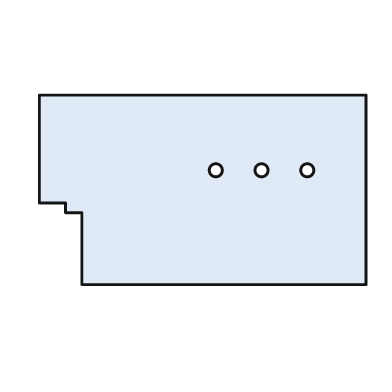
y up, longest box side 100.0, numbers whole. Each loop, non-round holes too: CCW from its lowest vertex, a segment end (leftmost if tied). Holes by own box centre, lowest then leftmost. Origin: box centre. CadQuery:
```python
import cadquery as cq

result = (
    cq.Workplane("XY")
    .moveTo(-37.0, -29.0)
    .lineTo(50.0, -29.0)
    .lineTo(50.0, 29.0)
    .lineTo(-50.0, 29.0)
    .lineTo(-50.0, -4.0)
    .lineTo(-42.0, -4.0)
    .lineTo(-42.0, -7.0)
    .lineTo(-37.0, -7.0)
    .close()
    .moveTo(4.0, 6.0)
    .circle(2.0)
    .moveTo(18.0, 6.0)
    .circle(2.0)
    .moveTo(32.0, 6.0)
    .circle(2.0)
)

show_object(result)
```